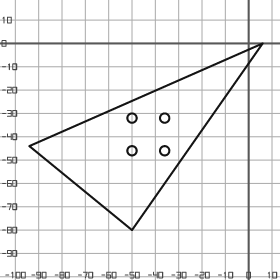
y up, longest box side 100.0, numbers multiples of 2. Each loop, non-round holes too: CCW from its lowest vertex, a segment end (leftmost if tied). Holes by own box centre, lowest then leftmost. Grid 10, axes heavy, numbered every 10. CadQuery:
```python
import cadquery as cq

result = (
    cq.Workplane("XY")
    .moveTo(-50.0, -80.0)
    .lineTo(6.0, 0.0)
    .lineTo(-94.0, -44.0)
    .close()
    .moveTo(-50.0, -46.0)
    .circle(2.0)
    .moveTo(-36.0, -46.0)
    .circle(2.0)
    .moveTo(-50.0, -32.0)
    .circle(2.0)
    .moveTo(-36.0, -32.0)
    .circle(2.0)
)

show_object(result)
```